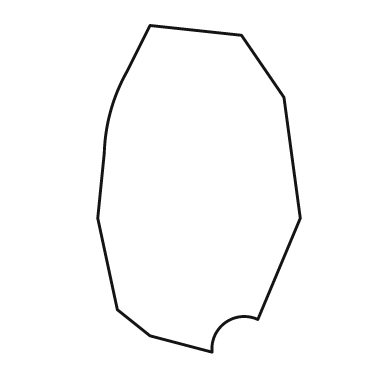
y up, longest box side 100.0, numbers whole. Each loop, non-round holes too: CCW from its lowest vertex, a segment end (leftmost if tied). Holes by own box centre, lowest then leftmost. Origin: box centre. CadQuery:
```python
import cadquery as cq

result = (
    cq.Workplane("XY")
    .moveTo(4.0, -50.0)
    .threePointArc((8.0, -41.0), (18.0, -40.0))
    .lineTo(31.0, -9.0)
    .lineTo(26.0, 28.0)
    .lineTo(13.0, 47.0)
    .lineTo(-15.0, 50.0)
    .lineTo(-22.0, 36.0)
    .threePointArc((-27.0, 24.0), (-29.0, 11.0))
    .lineTo(-31.0, -9.0)
    .lineTo(-25.0, -37.0)
    .lineTo(-15.0, -45.0)
    .close()
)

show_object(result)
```